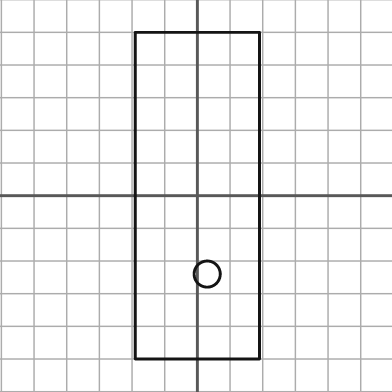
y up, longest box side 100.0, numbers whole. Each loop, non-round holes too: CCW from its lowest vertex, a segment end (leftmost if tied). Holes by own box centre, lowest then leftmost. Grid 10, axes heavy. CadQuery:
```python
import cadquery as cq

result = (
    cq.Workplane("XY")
    .moveTo(-19.0, -50.0)
    .lineTo(19.0, -50.0)
    .lineTo(19.0, 50.0)
    .lineTo(-19.0, 50.0)
    .close()
    .moveTo(3.0, -24.0)
    .circle(4.0)
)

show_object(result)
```